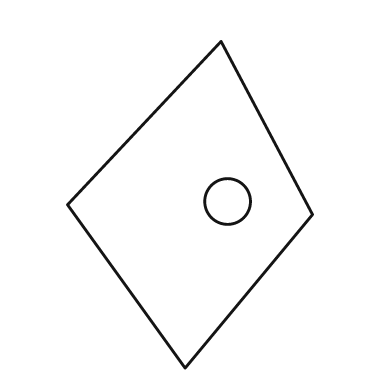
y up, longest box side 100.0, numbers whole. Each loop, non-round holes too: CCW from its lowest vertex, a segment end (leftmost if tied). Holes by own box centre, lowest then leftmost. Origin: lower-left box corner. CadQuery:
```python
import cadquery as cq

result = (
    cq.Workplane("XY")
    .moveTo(36.0, 0.0)
    .lineTo(75.0, 47.0)
    .lineTo(47.0, 100.0)
    .lineTo(0.0, 50.0)
    .close()
    .moveTo(49.0, 51.0)
    .circle(7.0)
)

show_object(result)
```